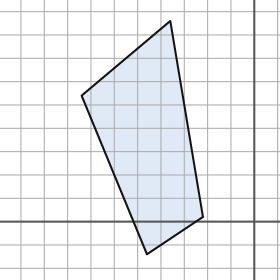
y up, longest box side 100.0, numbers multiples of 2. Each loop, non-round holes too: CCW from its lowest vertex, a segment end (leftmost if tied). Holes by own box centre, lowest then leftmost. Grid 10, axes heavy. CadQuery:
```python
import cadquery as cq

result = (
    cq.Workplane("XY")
    .moveTo(-46.0, -14.0)
    .lineTo(-22.0, 2.0)
    .lineTo(-36.0, 86.0)
    .lineTo(-74.0, 54.0)
    .close()
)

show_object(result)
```